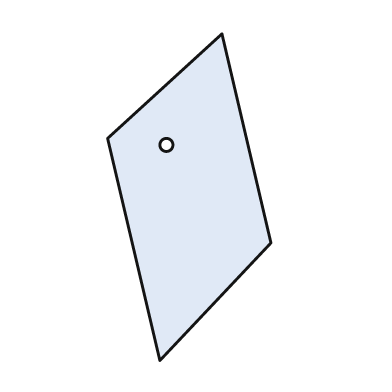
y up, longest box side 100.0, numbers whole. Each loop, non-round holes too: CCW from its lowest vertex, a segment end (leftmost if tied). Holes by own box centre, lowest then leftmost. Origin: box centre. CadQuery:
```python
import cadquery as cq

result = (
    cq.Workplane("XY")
    .moveTo(-9.0, -50.0)
    .lineTo(25.0, -14.0)
    .lineTo(10.0, 50.0)
    .lineTo(-25.0, 18.0)
    .close()
    .moveTo(-7.0, 16.0)
    .circle(2.0)
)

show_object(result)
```